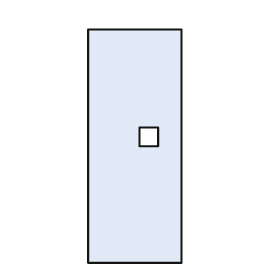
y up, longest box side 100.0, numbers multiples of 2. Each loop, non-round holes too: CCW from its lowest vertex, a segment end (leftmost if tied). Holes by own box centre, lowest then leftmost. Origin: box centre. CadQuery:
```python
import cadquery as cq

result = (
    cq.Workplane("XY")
    .moveTo(-20.0, -50.0)
    .lineTo(20.0, -50.0)
    .lineTo(20.0, 50.0)
    .lineTo(-20.0, 50.0)
    .close()
    .moveTo(2.0, 0.0)
    .lineTo(10.0, 0.0)
    .lineTo(10.0, 8.0)
    .lineTo(2.0, 8.0)
    .close()
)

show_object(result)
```